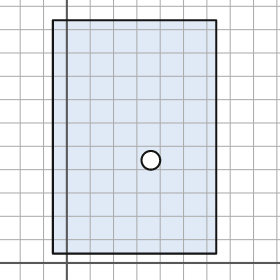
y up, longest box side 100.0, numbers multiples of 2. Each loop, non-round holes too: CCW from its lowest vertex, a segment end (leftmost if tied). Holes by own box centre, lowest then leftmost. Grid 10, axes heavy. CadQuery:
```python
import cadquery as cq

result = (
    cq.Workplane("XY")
    .moveTo(-6.0, 4.0)
    .lineTo(64.0, 4.0)
    .lineTo(64.0, 104.0)
    .lineTo(-6.0, 104.0)
    .close()
    .moveTo(36.0, 44.0)
    .circle(4.0)
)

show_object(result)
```